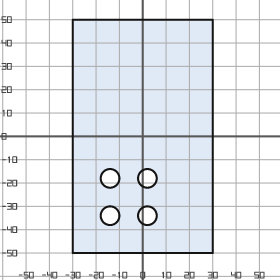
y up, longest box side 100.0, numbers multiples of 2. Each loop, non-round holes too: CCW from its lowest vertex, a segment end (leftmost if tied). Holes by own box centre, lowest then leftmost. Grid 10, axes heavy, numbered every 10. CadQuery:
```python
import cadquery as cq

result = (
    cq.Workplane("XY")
    .moveTo(-30.0, -50.0)
    .lineTo(30.0, -50.0)
    .lineTo(30.0, 50.0)
    .lineTo(-30.0, 50.0)
    .close()
    .moveTo(-14.0, -34.0)
    .circle(4.0)
    .moveTo(2.0, -34.0)
    .circle(4.0)
    .moveTo(-14.0, -18.0)
    .circle(4.0)
    .moveTo(2.0, -18.0)
    .circle(4.0)
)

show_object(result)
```